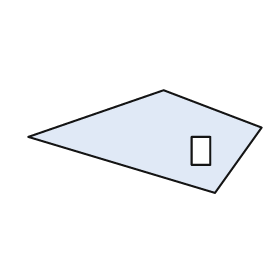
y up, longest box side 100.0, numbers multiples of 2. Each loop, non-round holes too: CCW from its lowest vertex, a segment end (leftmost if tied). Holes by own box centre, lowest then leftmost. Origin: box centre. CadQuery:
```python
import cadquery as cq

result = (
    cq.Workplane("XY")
    .moveTo(30.0, -22.0)
    .lineTo(50.0, 6.0)
    .lineTo(8.0, 22.0)
    .lineTo(-50.0, 2.0)
    .close()
    .moveTo(20.0, -10.0)
    .lineTo(28.0, -10.0)
    .lineTo(28.0, 2.0)
    .lineTo(20.0, 2.0)
    .close()
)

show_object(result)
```